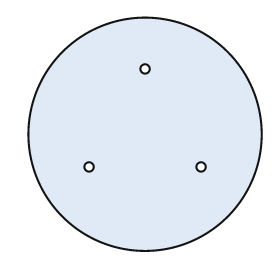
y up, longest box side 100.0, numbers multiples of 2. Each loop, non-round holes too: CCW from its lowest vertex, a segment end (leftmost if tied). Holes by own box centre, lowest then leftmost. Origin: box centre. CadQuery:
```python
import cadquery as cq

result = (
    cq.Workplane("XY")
    .moveTo(0.0, 0.0)
    .circle(50.0)
    .moveTo(-24.0, -14.0)
    .circle(2.0)
    .moveTo(24.0, -14.0)
    .circle(2.0)
    .moveTo(0.0, 28.0)
    .circle(2.0)
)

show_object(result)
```